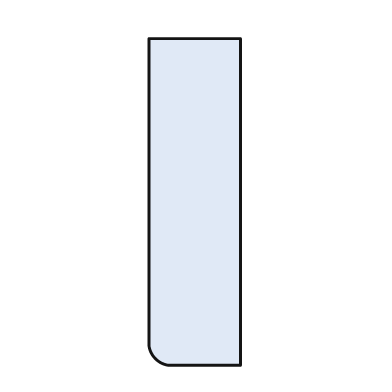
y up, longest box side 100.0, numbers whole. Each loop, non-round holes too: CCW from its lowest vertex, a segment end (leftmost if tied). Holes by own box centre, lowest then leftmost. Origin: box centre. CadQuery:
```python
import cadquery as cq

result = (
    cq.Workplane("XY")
    .moveTo(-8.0, -50.0)
    .lineTo(14.0, -50.0)
    .lineTo(14.0, 50.0)
    .lineTo(-14.0, 50.0)
    .lineTo(-14.0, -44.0)
    .threePointArc((-12.0, -48.0), (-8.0, -50.0))
    .close()
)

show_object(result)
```